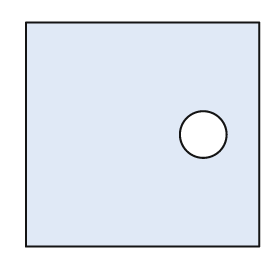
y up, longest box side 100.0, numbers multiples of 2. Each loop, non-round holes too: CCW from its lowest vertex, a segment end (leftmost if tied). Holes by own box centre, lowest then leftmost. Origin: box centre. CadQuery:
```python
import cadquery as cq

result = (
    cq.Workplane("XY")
    .moveTo(-50.0, -48.0)
    .lineTo(50.0, -48.0)
    .lineTo(50.0, 48.0)
    .lineTo(-50.0, 48.0)
    .close()
    .moveTo(26.0, 0.0)
    .circle(10.0)
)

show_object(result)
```